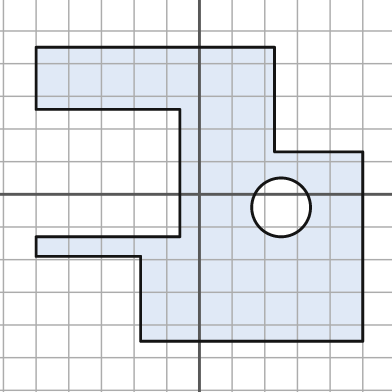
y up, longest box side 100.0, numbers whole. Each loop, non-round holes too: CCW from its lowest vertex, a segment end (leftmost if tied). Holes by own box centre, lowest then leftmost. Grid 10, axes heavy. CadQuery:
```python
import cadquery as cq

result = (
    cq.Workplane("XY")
    .moveTo(-18.0, -45.0)
    .lineTo(50.0, -45.0)
    .lineTo(50.0, 13.0)
    .lineTo(23.0, 13.0)
    .lineTo(23.0, 45.0)
    .lineTo(-50.0, 45.0)
    .lineTo(-50.0, 26.0)
    .lineTo(-6.0, 26.0)
    .lineTo(-6.0, -13.0)
    .lineTo(-50.0, -13.0)
    .lineTo(-50.0, -19.0)
    .lineTo(-18.0, -19.0)
    .close()
    .moveTo(25.0, -4.0)
    .circle(9.0)
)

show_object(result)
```